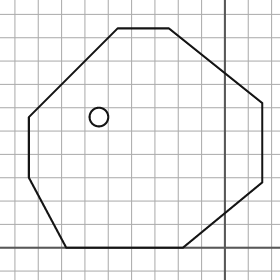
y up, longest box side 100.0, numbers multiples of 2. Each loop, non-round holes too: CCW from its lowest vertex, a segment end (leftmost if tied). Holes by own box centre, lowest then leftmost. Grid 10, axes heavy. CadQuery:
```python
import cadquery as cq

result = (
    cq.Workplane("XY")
    .moveTo(-68.0, 0.0)
    .lineTo(-18.0, 0.0)
    .lineTo(16.0, 28.0)
    .lineTo(16.0, 62.0)
    .lineTo(-24.0, 94.0)
    .lineTo(-46.0, 94.0)
    .lineTo(-84.0, 56.0)
    .lineTo(-84.0, 30.0)
    .close()
    .moveTo(-54.0, 56.0)
    .circle(4.0)
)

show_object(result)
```